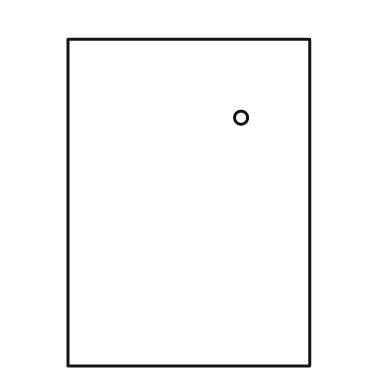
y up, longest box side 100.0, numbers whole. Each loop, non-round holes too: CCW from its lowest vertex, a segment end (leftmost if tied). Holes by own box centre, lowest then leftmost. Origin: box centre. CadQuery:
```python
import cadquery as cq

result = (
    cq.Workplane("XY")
    .moveTo(-37.0, -50.0)
    .lineTo(37.0, -50.0)
    .lineTo(37.0, 50.0)
    .lineTo(-37.0, 50.0)
    .close()
    .moveTo(16.0, 26.0)
    .circle(2.0)
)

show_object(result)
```